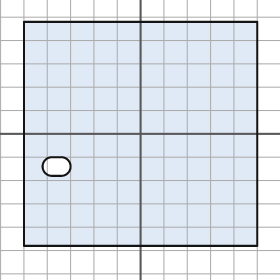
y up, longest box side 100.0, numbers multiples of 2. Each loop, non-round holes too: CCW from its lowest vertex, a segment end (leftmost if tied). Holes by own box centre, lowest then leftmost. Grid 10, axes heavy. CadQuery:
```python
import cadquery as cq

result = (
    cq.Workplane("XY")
    .moveTo(-50.0, -48.0)
    .lineTo(50.0, -48.0)
    .lineTo(50.0, 48.0)
    .lineTo(-50.0, 48.0)
    .close()
    .moveTo(-38.0, -18.0)
    .lineTo(-34.0, -18.0)
    .threePointArc((-30.0, -14.0), (-34.0, -10.0))
    .lineTo(-38.0, -10.0)
    .threePointArc((-42.0, -14.0), (-38.0, -18.0))
    .close()
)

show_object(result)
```